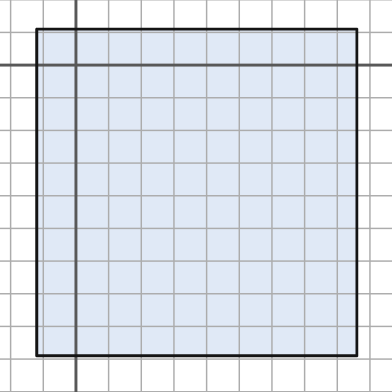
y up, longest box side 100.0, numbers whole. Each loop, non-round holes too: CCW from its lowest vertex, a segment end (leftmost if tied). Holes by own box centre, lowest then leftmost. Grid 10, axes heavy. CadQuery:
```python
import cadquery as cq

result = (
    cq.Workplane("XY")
    .moveTo(-12.0, -89.0)
    .lineTo(86.0, -89.0)
    .lineTo(86.0, 11.0)
    .lineTo(-12.0, 11.0)
    .close()
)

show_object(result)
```